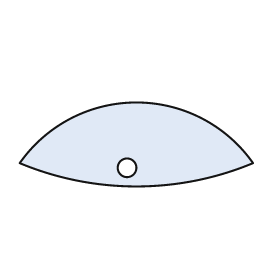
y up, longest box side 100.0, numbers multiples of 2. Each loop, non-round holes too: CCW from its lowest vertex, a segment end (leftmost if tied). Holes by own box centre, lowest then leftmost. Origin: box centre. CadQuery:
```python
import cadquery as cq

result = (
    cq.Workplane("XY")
    .moveTo(-50.0, -8.0)
    .threePointArc((0.0, -18.0), (50.0, -8.0))
    .threePointArc((0.0, 18.0), (-50.0, -8.0))
    .close()
    .moveTo(-4.0, -10.0)
    .circle(4.0)
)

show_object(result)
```